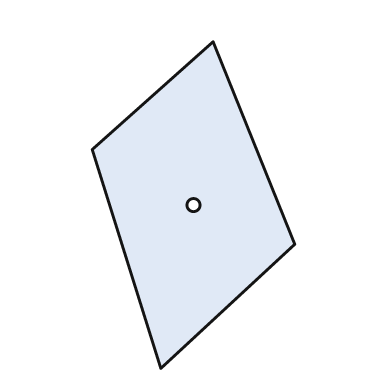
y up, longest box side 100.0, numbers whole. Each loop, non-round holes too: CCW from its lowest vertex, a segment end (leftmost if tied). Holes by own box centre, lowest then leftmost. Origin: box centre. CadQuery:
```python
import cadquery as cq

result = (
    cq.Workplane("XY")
    .moveTo(-10.0, -50.0)
    .lineTo(31.0, -12.0)
    .lineTo(6.0, 50.0)
    .lineTo(-31.0, 17.0)
    .close()
    .moveTo(0.0, 0.0)
    .circle(2.0)
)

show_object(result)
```